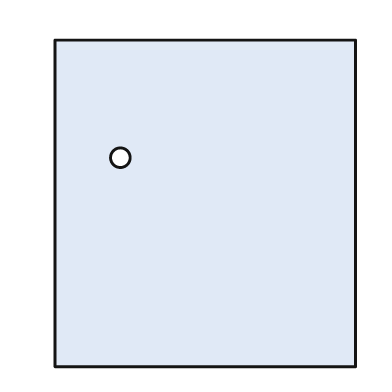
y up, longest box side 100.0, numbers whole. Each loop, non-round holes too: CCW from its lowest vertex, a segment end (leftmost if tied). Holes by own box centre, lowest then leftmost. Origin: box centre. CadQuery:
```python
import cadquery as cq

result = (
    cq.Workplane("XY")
    .moveTo(-46.0, -50.0)
    .lineTo(46.0, -50.0)
    .lineTo(46.0, 50.0)
    .lineTo(-46.0, 50.0)
    .close()
    .moveTo(-26.0, 14.0)
    .circle(3.0)
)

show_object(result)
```